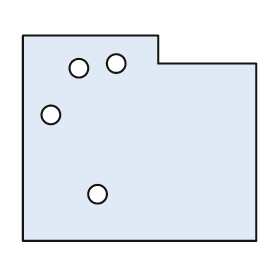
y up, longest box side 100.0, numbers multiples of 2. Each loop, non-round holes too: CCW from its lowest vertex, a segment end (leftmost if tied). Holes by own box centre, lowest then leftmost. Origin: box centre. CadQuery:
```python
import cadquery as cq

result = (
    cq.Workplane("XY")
    .moveTo(-50.0, -44.0)
    .lineTo(50.0, -44.0)
    .lineTo(50.0, 32.0)
    .lineTo(8.0, 32.0)
    .lineTo(8.0, 44.0)
    .lineTo(-50.0, 44.0)
    .close()
    .moveTo(-18.0, -24.0)
    .circle(4.0)
    .moveTo(-38.0, 10.0)
    .circle(4.0)
    .moveTo(-26.0, 30.0)
    .circle(4.0)
    .moveTo(-10.0, 32.0)
    .circle(4.0)
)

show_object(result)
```